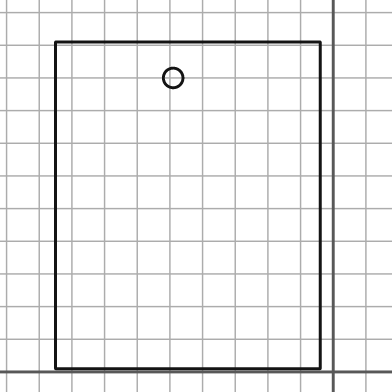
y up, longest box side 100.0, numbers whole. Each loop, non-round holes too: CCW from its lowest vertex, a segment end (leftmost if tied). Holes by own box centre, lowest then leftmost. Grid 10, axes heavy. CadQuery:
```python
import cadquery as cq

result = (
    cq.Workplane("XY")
    .moveTo(-85.0, 1.0)
    .lineTo(-4.0, 1.0)
    .lineTo(-4.0, 101.0)
    .lineTo(-85.0, 101.0)
    .close()
    .moveTo(-49.0, 90.0)
    .circle(3.0)
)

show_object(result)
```